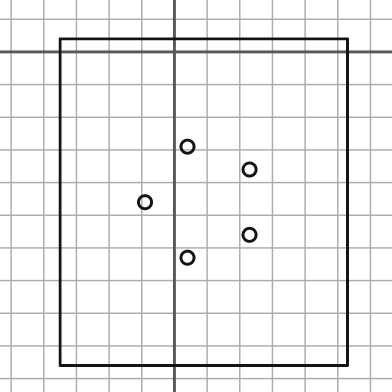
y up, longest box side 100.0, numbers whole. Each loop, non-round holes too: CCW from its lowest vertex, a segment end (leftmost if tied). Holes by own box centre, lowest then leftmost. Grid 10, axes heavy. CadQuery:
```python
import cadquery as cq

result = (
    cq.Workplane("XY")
    .moveTo(-35.0, -96.0)
    .lineTo(53.0, -96.0)
    .lineTo(53.0, 4.0)
    .lineTo(-35.0, 4.0)
    .close()
    .moveTo(4.0, -63.0)
    .circle(2.0)
    .moveTo(23.0, -56.0)
    .circle(2.0)
    .moveTo(-9.0, -46.0)
    .circle(2.0)
    .moveTo(23.0, -36.0)
    .circle(2.0)
    .moveTo(4.0, -29.0)
    .circle(2.0)
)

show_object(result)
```